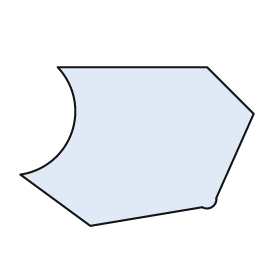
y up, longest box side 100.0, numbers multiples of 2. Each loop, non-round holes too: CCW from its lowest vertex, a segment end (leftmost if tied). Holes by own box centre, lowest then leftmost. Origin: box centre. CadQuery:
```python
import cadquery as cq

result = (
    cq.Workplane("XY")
    .moveTo(-20.0, -34.0)
    .lineTo(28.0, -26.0)
    .threePointArc((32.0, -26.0), (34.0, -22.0))
    .lineTo(50.0, 14.0)
    .lineTo(30.0, 34.0)
    .lineTo(-34.0, 34.0)
    .threePointArc((-28.0, 6.0), (-50.0, -12.0))
    .close()
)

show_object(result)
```